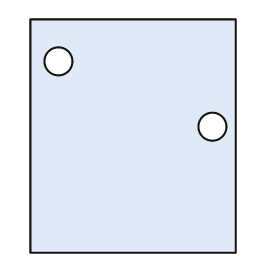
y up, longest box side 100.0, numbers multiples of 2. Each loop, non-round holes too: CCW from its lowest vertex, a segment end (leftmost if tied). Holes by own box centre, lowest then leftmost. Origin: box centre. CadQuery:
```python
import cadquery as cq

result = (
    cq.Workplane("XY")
    .moveTo(-44.0, -50.0)
    .lineTo(44.0, -50.0)
    .lineTo(44.0, 50.0)
    .lineTo(-44.0, 50.0)
    .close()
    .moveTo(34.0, 4.0)
    .circle(6.0)
    .moveTo(-32.0, 32.0)
    .circle(6.0)
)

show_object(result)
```